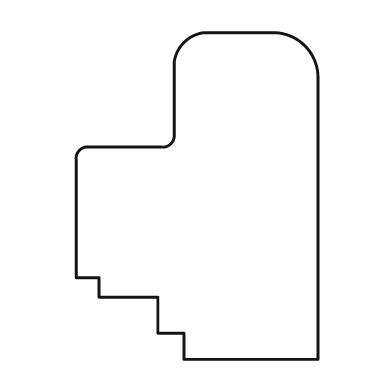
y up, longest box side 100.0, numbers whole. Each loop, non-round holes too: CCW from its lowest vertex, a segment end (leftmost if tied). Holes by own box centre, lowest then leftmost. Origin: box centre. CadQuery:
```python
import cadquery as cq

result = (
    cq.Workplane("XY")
    .moveTo(-4.0, -50.0)
    .lineTo(37.0, -50.0)
    .lineTo(37.0, 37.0)
    .threePointArc((33.0, 46.0), (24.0, 50.0))
    .lineTo(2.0, 50.0)
    .threePointArc((-4.0, 47.0), (-7.0, 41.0))
    .lineTo(-7.0, 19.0)
    .threePointArc((-8.0, 16.0), (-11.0, 15.0))
    .lineTo(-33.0, 15.0)
    .threePointArc((-36.0, 14.0), (-37.0, 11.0))
    .lineTo(-37.0, -25.0)
    .lineTo(-30.0, -25.0)
    .lineTo(-30.0, -31.0)
    .lineTo(-12.0, -31.0)
    .lineTo(-12.0, -42.0)
    .lineTo(-4.0, -42.0)
    .close()
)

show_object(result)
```